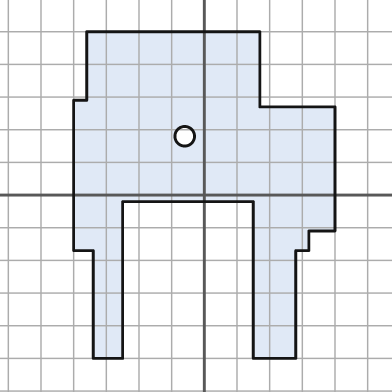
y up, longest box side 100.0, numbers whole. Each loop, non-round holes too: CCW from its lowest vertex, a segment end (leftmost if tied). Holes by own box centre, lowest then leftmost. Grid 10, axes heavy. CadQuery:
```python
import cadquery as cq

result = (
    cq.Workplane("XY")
    .moveTo(-34.0, -50.0)
    .lineTo(-25.0, -50.0)
    .lineTo(-25.0, -2.0)
    .lineTo(15.0, -2.0)
    .lineTo(15.0, -50.0)
    .lineTo(28.0, -50.0)
    .lineTo(28.0, -17.0)
    .lineTo(32.0, -17.0)
    .lineTo(32.0, -11.0)
    .lineTo(40.0, -11.0)
    .lineTo(40.0, 27.0)
    .lineTo(17.0, 27.0)
    .lineTo(17.0, 50.0)
    .lineTo(-36.0, 50.0)
    .lineTo(-36.0, 29.0)
    .lineTo(-40.0, 29.0)
    .lineTo(-40.0, -17.0)
    .lineTo(-34.0, -17.0)
    .close()
    .moveTo(-6.0, 18.0)
    .circle(3.0)
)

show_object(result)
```